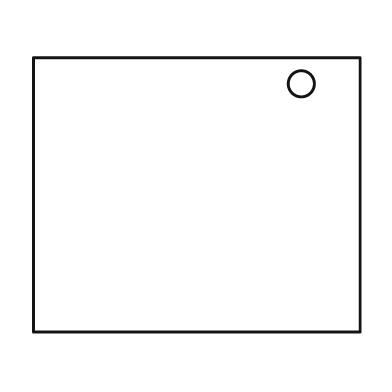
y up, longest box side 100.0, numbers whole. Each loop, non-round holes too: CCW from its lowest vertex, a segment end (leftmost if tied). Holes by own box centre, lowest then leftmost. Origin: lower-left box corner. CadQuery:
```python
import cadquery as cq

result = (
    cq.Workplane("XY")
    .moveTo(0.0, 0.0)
    .lineTo(100.0, 0.0)
    .lineTo(100.0, 84.0)
    .lineTo(0.0, 84.0)
    .close()
    .moveTo(82.0, 76.0)
    .circle(4.0)
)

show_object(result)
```